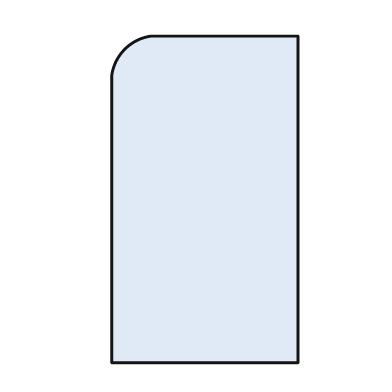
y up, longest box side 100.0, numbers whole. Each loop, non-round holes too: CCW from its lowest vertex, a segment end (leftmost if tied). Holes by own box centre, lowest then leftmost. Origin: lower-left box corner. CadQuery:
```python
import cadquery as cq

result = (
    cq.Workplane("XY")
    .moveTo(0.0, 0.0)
    .lineTo(57.0, 0.0)
    .lineTo(57.0, 100.0)
    .lineTo(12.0, 100.0)
    .threePointArc((4.0, 96.0), (0.0, 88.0))
    .close()
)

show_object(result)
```